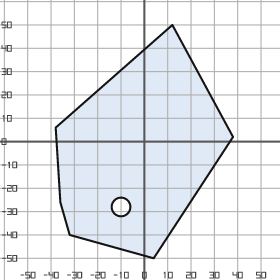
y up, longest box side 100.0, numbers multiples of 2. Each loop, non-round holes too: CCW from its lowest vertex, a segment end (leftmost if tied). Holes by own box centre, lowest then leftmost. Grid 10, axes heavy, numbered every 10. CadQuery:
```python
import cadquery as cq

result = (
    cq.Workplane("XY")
    .moveTo(4.0, -50.0)
    .lineTo(38.0, 2.0)
    .lineTo(12.0, 50.0)
    .lineTo(-38.0, 6.0)
    .lineTo(-36.0, -26.0)
    .lineTo(-32.0, -40.0)
    .close()
    .moveTo(-10.0, -28.0)
    .circle(4.0)
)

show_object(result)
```